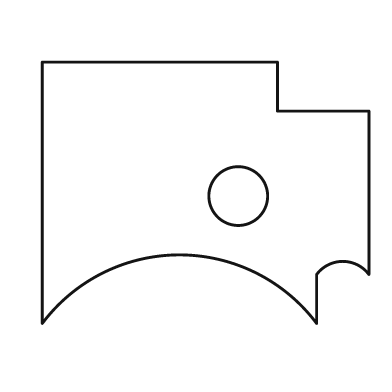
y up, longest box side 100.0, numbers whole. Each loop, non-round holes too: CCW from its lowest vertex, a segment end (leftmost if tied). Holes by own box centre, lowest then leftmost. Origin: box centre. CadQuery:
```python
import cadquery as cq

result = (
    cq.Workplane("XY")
    .moveTo(-50.0, -40.0)
    .threePointArc((-8.0, -19.0), (34.0, -40.0))
    .lineTo(34.0, -25.0)
    .threePointArc((42.0, -21.0), (50.0, -25.0))
    .lineTo(50.0, 25.0)
    .lineTo(22.0, 25.0)
    .lineTo(22.0, 40.0)
    .lineTo(-50.0, 40.0)
    .close()
    .moveTo(10.0, -1.0)
    .circle(9.0)
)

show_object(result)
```